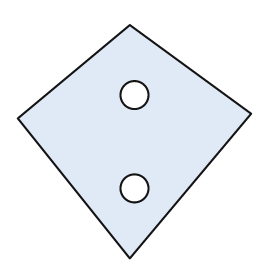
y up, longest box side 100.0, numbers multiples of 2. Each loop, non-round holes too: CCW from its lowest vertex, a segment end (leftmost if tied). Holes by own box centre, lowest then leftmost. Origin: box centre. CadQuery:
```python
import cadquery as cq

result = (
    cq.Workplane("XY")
    .moveTo(-2.0, -50.0)
    .lineTo(50.0, 12.0)
    .lineTo(-2.0, 50.0)
    .lineTo(-50.0, 10.0)
    .close()
    .moveTo(0.0, -20.0)
    .circle(6.0)
    .moveTo(0.0, 20.0)
    .circle(6.0)
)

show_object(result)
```